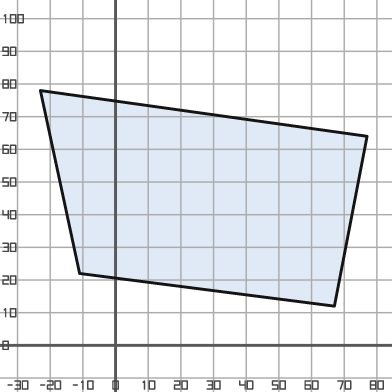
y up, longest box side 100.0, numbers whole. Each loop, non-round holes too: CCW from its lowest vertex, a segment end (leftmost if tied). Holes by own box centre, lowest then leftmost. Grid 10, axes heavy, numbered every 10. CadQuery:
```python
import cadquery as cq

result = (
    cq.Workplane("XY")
    .moveTo(67.0, 12.0)
    .lineTo(77.0, 64.0)
    .lineTo(-23.0, 78.0)
    .lineTo(-11.0, 22.0)
    .close()
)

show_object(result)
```